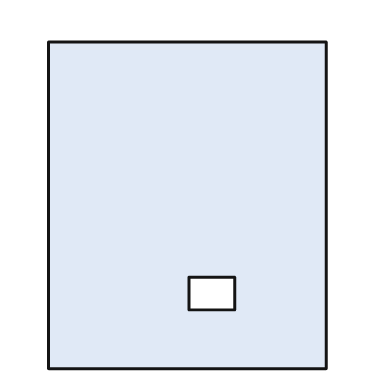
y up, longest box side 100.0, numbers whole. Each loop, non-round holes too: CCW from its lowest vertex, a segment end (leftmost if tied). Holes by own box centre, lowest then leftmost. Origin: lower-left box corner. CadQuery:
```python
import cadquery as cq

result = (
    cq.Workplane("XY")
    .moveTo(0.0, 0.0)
    .lineTo(85.0, 0.0)
    .lineTo(85.0, 100.0)
    .lineTo(0.0, 100.0)
    .close()
    .moveTo(43.0, 18.0)
    .lineTo(57.0, 18.0)
    .lineTo(57.0, 28.0)
    .lineTo(43.0, 28.0)
    .close()
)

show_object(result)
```